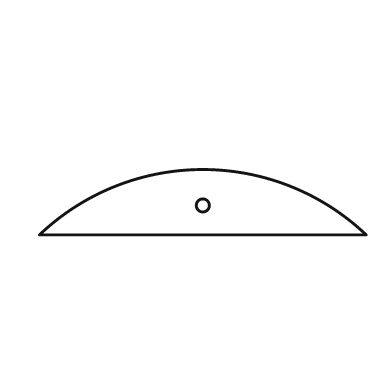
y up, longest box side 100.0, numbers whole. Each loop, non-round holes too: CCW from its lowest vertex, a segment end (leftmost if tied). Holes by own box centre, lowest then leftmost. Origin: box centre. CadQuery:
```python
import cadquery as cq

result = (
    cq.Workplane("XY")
    .moveTo(-50.0, -10.0)
    .lineTo(50.0, -10.0)
    .threePointArc((0.0, 10.0), (-50.0, -10.0))
    .close()
    .moveTo(0.0, -1.0)
    .circle(2.0)
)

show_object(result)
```